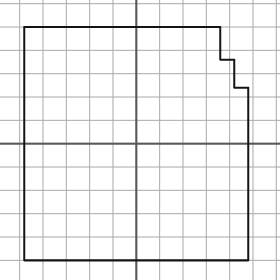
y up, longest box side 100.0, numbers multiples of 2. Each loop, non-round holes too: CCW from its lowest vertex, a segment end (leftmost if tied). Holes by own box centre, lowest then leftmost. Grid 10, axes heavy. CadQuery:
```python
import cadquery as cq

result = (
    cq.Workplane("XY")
    .moveTo(-48.0, -50.0)
    .lineTo(48.0, -50.0)
    .lineTo(48.0, 24.0)
    .lineTo(42.0, 24.0)
    .lineTo(42.0, 36.0)
    .lineTo(36.0, 36.0)
    .lineTo(36.0, 50.0)
    .lineTo(-48.0, 50.0)
    .close()
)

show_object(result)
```